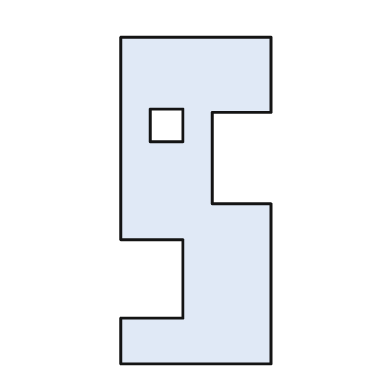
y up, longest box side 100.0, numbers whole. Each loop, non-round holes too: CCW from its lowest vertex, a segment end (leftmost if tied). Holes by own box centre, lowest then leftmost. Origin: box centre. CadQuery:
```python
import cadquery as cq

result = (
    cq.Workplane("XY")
    .moveTo(-23.0, -50.0)
    .lineTo(23.0, -50.0)
    .lineTo(23.0, -1.0)
    .lineTo(5.0, -1.0)
    .lineTo(5.0, 27.0)
    .lineTo(23.0, 27.0)
    .lineTo(23.0, 50.0)
    .lineTo(-23.0, 50.0)
    .lineTo(-23.0, -12.0)
    .lineTo(-4.0, -12.0)
    .lineTo(-4.0, -36.0)
    .lineTo(-23.0, -36.0)
    .close()
    .moveTo(-14.0, 18.0)
    .lineTo(-4.0, 18.0)
    .lineTo(-4.0, 28.0)
    .lineTo(-14.0, 28.0)
    .close()
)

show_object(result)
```